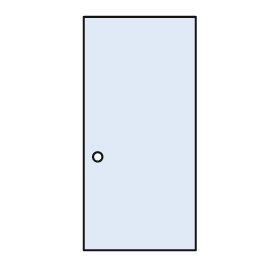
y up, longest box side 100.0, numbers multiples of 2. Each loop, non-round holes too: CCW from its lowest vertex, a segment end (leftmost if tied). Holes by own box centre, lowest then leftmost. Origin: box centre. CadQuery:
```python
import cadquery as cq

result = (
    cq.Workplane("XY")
    .moveTo(-24.0, -50.0)
    .lineTo(24.0, -50.0)
    .lineTo(24.0, 50.0)
    .lineTo(-24.0, 50.0)
    .close()
    .moveTo(-18.0, -10.0)
    .circle(2.0)
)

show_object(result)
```